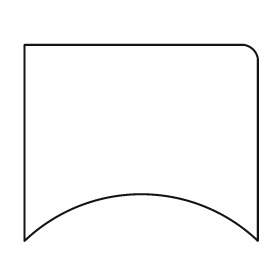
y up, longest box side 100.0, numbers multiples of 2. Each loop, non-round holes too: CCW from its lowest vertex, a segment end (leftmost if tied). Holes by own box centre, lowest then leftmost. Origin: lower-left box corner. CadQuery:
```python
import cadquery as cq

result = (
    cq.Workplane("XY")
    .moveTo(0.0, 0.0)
    .threePointArc((50.0, 20.0), (100.0, 0.0))
    .lineTo(100.0, 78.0)
    .threePointArc((98.0, 82.0), (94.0, 84.0))
    .lineTo(0.0, 84.0)
    .close()
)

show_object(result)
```